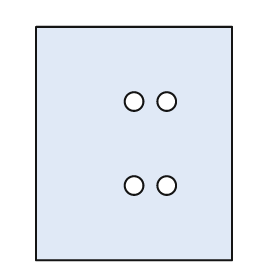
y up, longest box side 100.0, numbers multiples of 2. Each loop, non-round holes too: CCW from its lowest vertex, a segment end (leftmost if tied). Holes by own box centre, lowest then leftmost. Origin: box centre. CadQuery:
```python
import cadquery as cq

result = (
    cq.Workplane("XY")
    .moveTo(-42.0, -50.0)
    .lineTo(42.0, -50.0)
    .lineTo(42.0, 50.0)
    .lineTo(-42.0, 50.0)
    .close()
    .moveTo(0.0, -18.0)
    .circle(4.0)
    .moveTo(14.0, -18.0)
    .circle(4.0)
    .moveTo(0.0, 18.0)
    .circle(4.0)
    .moveTo(14.0, 18.0)
    .circle(4.0)
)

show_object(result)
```